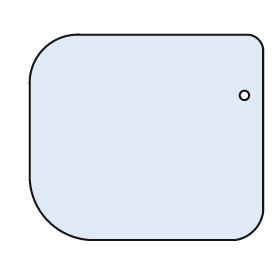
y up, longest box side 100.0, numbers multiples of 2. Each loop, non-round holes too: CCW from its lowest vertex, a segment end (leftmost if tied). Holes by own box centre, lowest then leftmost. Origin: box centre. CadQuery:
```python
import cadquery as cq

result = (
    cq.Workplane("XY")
    .moveTo(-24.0, -44.0)
    .lineTo(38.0, -44.0)
    .threePointArc((46.0, -40.0), (50.0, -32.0))
    .lineTo(50.0, 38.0)
    .threePointArc((48.0, 42.0), (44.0, 44.0))
    .lineTo(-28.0, 44.0)
    .threePointArc((-44.0, 38.0), (-50.0, 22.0))
    .lineTo(-50.0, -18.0)
    .threePointArc((-42.0, -36.0), (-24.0, -44.0))
    .close()
    .moveTo(42.0, 18.0)
    .circle(2.0)
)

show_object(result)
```